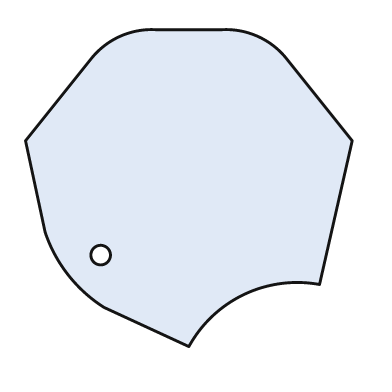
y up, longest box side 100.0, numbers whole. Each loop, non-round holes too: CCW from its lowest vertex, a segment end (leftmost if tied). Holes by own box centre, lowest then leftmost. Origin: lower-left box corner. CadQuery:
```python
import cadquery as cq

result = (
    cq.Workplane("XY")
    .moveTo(50.0, 0.0)
    .threePointArc((67.0, 16.0), (90.0, 19.0))
    .lineTo(100.0, 63.0)
    .lineTo(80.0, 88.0)
    .threePointArc((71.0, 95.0), (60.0, 97.0))
    .lineTo(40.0, 97.0)
    .threePointArc((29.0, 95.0), (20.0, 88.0))
    .lineTo(0.0, 63.0)
    .lineTo(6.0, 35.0)
    .threePointArc((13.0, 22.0), (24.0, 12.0))
    .close()
    .moveTo(23.0, 28.0)
    .circle(3.0)
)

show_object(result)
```